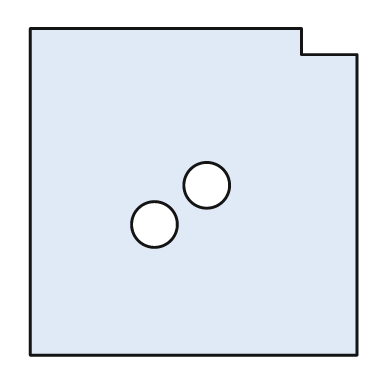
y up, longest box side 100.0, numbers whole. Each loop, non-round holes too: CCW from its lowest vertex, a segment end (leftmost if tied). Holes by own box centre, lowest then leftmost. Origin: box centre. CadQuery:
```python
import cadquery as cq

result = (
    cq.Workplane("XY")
    .moveTo(-50.0, -50.0)
    .lineTo(50.0, -50.0)
    .lineTo(50.0, 42.0)
    .lineTo(33.0, 42.0)
    .lineTo(33.0, 50.0)
    .lineTo(-50.0, 50.0)
    .close()
    .moveTo(-12.0, -10.0)
    .circle(7.0)
    .moveTo(4.0, 2.0)
    .circle(7.0)
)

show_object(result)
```